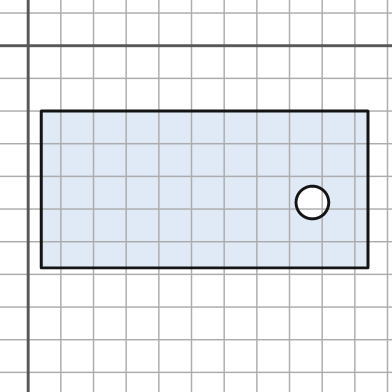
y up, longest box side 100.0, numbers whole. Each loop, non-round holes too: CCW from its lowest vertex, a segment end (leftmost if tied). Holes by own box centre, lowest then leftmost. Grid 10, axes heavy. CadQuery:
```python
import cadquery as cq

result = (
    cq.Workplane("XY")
    .moveTo(4.0, -68.0)
    .lineTo(104.0, -68.0)
    .lineTo(104.0, -20.0)
    .lineTo(4.0, -20.0)
    .close()
    .moveTo(87.0, -48.0)
    .circle(5.0)
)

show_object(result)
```